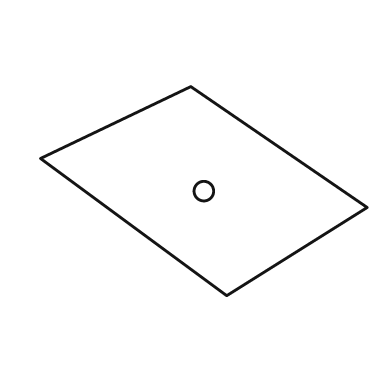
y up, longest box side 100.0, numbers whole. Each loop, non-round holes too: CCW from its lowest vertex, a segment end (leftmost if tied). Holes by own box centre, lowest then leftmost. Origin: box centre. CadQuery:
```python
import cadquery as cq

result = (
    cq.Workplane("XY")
    .moveTo(7.0, -32.0)
    .lineTo(50.0, -5.0)
    .lineTo(-4.0, 32.0)
    .lineTo(-50.0, 10.0)
    .close()
    .moveTo(0.0, 0.0)
    .circle(3.0)
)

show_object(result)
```